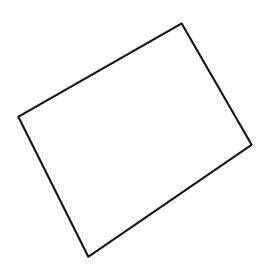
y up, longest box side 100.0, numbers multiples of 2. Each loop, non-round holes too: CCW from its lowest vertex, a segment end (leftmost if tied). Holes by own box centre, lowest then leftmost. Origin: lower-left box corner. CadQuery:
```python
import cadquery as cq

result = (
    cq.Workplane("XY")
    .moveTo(30.0, 0.0)
    .lineTo(100.0, 48.0)
    .lineTo(70.0, 100.0)
    .lineTo(0.0, 60.0)
    .close()
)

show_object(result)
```